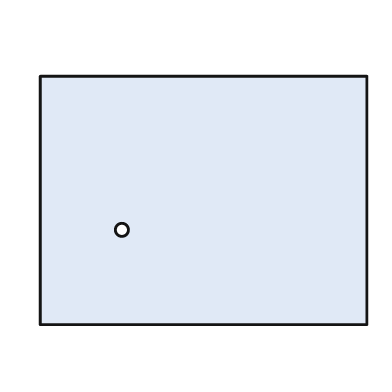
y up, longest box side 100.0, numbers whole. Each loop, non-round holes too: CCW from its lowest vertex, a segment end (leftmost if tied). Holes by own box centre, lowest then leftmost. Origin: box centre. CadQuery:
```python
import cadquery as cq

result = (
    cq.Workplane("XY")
    .moveTo(-50.0, -38.0)
    .lineTo(50.0, -38.0)
    .lineTo(50.0, 38.0)
    .lineTo(-50.0, 38.0)
    .close()
    .moveTo(-25.0, -9.0)
    .circle(2.0)
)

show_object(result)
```